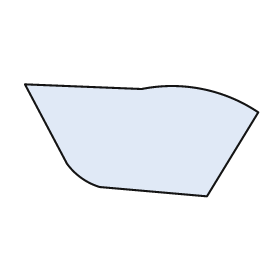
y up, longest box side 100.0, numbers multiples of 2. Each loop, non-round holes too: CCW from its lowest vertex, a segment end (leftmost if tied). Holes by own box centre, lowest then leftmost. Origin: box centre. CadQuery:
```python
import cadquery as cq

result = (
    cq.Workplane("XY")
    .moveTo(28.0, -24.0)
    .lineTo(50.0, 12.0)
    .threePointArc((26.0, 22.0), (0.0, 22.0))
    .lineTo(-50.0, 24.0)
    .lineTo(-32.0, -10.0)
    .threePointArc((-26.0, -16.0), (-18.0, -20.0))
    .close()
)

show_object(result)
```